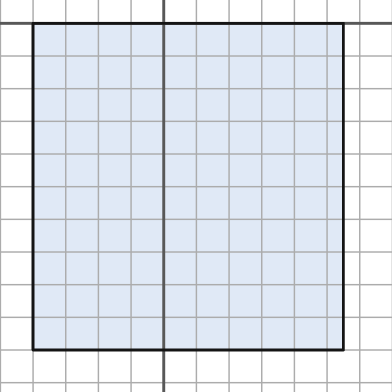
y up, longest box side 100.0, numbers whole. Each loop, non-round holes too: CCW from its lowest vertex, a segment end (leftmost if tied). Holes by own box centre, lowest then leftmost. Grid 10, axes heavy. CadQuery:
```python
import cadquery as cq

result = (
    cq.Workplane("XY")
    .moveTo(-40.0, -100.0)
    .lineTo(55.0, -100.0)
    .lineTo(55.0, 0.0)
    .lineTo(-40.0, 0.0)
    .close()
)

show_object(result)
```